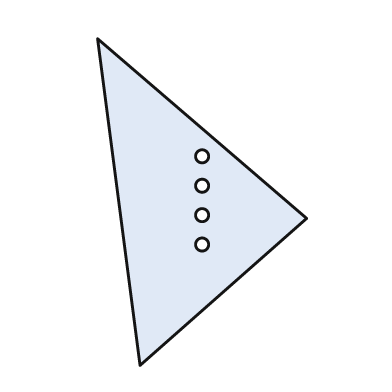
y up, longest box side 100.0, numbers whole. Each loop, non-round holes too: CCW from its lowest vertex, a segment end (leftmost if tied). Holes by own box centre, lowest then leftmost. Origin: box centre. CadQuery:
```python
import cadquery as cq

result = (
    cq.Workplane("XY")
    .moveTo(-19.0, -50.0)
    .lineTo(32.0, -5.0)
    .lineTo(-32.0, 50.0)
    .close()
    .moveTo(0.0, -13.0)
    .circle(2.0)
    .moveTo(0.0, -4.0)
    .circle(2.0)
    .moveTo(0.0, 5.0)
    .circle(2.0)
    .moveTo(0.0, 14.0)
    .circle(2.0)
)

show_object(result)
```